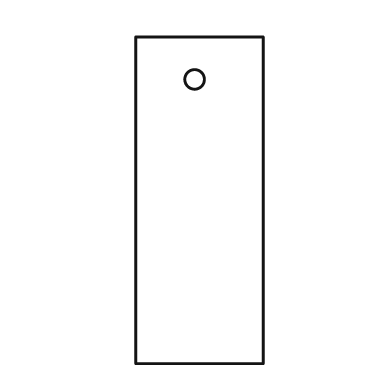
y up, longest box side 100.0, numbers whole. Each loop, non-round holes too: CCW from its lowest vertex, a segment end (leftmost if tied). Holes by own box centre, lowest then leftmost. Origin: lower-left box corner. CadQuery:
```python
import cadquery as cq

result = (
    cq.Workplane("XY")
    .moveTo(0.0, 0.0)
    .lineTo(39.0, 0.0)
    .lineTo(39.0, 100.0)
    .lineTo(0.0, 100.0)
    .close()
    .moveTo(18.0, 87.0)
    .circle(3.0)
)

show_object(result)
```